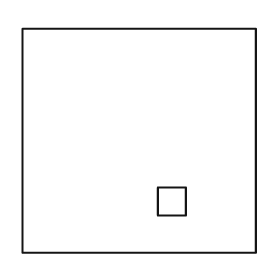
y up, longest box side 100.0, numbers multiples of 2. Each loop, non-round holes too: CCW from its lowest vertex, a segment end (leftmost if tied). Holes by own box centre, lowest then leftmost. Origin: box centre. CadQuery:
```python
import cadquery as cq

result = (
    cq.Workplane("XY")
    .moveTo(-50.0, -48.0)
    .lineTo(50.0, -48.0)
    .lineTo(50.0, 48.0)
    .lineTo(-50.0, 48.0)
    .close()
    .moveTo(8.0, -32.0)
    .lineTo(20.0, -32.0)
    .lineTo(20.0, -20.0)
    .lineTo(8.0, -20.0)
    .close()
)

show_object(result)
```